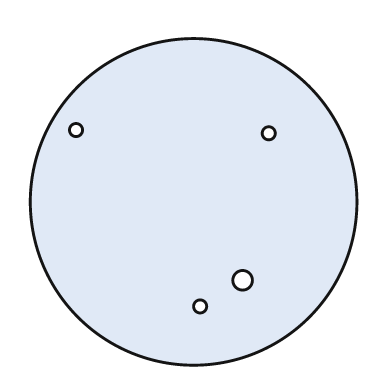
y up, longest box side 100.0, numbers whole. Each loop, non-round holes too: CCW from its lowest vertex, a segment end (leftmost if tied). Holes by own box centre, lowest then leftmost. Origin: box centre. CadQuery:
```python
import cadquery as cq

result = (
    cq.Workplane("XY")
    .moveTo(0.0, 0.0)
    .circle(50.0)
    .moveTo(2.0, -32.0)
    .circle(2.0)
    .moveTo(15.0, -24.0)
    .circle(3.0)
    .moveTo(23.0, 21.0)
    .circle(2.0)
    .moveTo(-36.0, 22.0)
    .circle(2.0)
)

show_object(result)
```